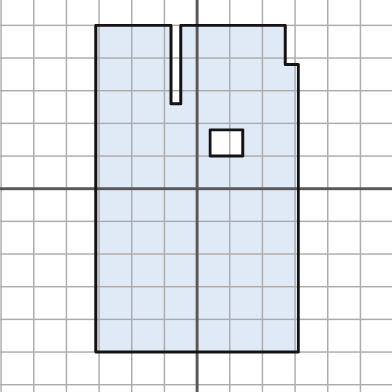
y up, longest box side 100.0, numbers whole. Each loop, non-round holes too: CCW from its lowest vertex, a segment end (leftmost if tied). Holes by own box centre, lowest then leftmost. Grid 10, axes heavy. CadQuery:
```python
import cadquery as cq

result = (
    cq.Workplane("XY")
    .moveTo(-31.0, -50.0)
    .lineTo(31.0, -50.0)
    .lineTo(31.0, 38.0)
    .lineTo(27.0, 38.0)
    .lineTo(27.0, 50.0)
    .lineTo(-5.0, 50.0)
    .lineTo(-5.0, 26.0)
    .lineTo(-8.0, 26.0)
    .lineTo(-8.0, 50.0)
    .lineTo(-31.0, 50.0)
    .close()
    .moveTo(4.0, 10.0)
    .lineTo(14.0, 10.0)
    .lineTo(14.0, 18.0)
    .lineTo(4.0, 18.0)
    .close()
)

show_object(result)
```